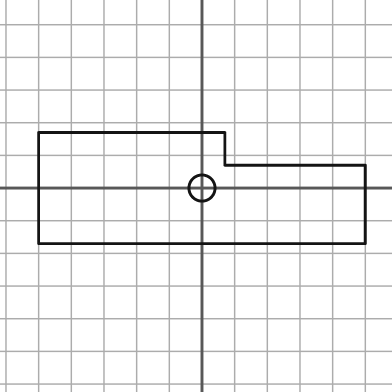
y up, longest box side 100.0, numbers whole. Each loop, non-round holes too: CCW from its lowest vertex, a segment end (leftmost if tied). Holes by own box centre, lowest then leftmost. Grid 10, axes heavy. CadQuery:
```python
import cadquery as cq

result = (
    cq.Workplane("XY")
    .moveTo(-50.0, -17.0)
    .lineTo(50.0, -17.0)
    .lineTo(50.0, 7.0)
    .lineTo(7.0, 7.0)
    .lineTo(7.0, 17.0)
    .lineTo(-50.0, 17.0)
    .close()
    .moveTo(0.0, 0.0)
    .circle(4.0)
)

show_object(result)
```